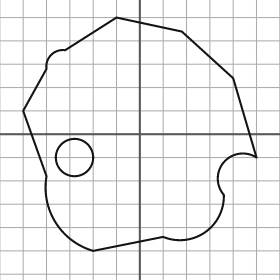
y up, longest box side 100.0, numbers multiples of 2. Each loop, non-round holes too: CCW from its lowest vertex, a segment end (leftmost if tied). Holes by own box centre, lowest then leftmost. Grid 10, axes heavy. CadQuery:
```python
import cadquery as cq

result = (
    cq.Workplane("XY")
    .moveTo(-20.0, -50.0)
    .lineTo(10.0, -44.0)
    .threePointArc((28.0, -42.0), (36.0, -26.0))
    .threePointArc((36.0, -12.0), (50.0, -10.0))
    .lineTo(40.0, 24.0)
    .lineTo(18.0, 44.0)
    .lineTo(-10.0, 50.0)
    .lineTo(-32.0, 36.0)
    .threePointArc((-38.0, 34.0), (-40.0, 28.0))
    .lineTo(-50.0, 10.0)
    .lineTo(-40.0, -18.0)
    .threePointArc((-36.0, -38.0), (-20.0, -50.0))
    .close()
    .moveTo(-28.0, -10.0)
    .circle(8.0)
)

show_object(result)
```